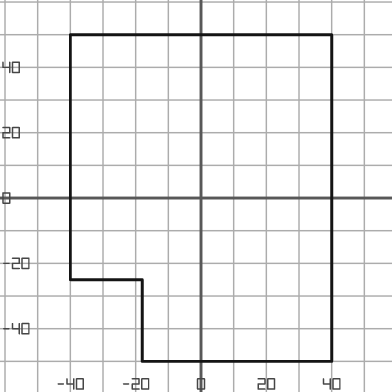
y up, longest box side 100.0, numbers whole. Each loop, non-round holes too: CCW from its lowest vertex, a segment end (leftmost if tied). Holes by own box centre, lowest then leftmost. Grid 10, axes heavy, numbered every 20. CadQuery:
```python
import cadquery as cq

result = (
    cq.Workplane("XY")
    .moveTo(-18.0, -50.0)
    .lineTo(40.0, -50.0)
    .lineTo(40.0, 50.0)
    .lineTo(-40.0, 50.0)
    .lineTo(-40.0, -25.0)
    .lineTo(-18.0, -25.0)
    .close()
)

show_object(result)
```